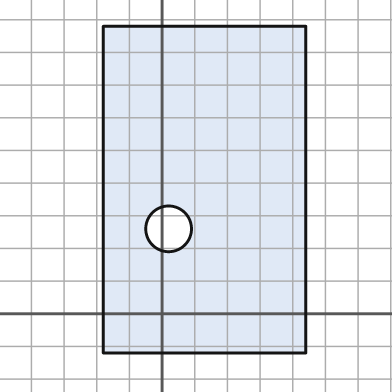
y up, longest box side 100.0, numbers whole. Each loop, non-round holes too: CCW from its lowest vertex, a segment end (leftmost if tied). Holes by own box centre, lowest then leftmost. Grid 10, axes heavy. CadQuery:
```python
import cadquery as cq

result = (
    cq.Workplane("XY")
    .moveTo(-18.0, -12.0)
    .lineTo(44.0, -12.0)
    .lineTo(44.0, 88.0)
    .lineTo(-18.0, 88.0)
    .close()
    .moveTo(2.0, 26.0)
    .circle(7.0)
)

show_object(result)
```